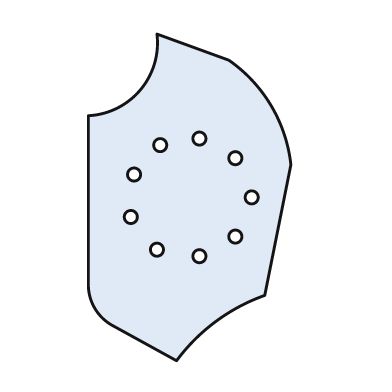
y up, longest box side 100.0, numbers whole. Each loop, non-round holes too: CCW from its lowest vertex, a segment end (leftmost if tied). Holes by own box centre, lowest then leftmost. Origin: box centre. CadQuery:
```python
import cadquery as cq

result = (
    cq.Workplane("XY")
    .moveTo(-4.0, -50.0)
    .threePointArc((8.0, -38.0), (23.0, -30.0))
    .lineTo(31.0, 10.0)
    .threePointArc((25.0, 28.0), (12.0, 42.0))
    .lineTo(-10.0, 50.0)
    .threePointArc((-15.0, 33.0), (-31.0, 25.0))
    .lineTo(-31.0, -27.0)
    .threePointArc((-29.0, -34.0), (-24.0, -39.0))
    .close()
    .moveTo(3.0, -18.0)
    .circle(2.0)
    .moveTo(-10.0, -16.0)
    .circle(2.0)
    .moveTo(14.0, -12.0)
    .circle(2.0)
    .moveTo(-18.0, -6.0)
    .circle(2.0)
    .moveTo(19.0, 0.0)
    .circle(2.0)
    .moveTo(-17.0, 7.0)
    .circle(2.0)
    .moveTo(14.0, 12.0)
    .circle(2.0)
    .moveTo(-9.0, 16.0)
    .circle(2.0)
    .moveTo(3.0, 18.0)
    .circle(2.0)
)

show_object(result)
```